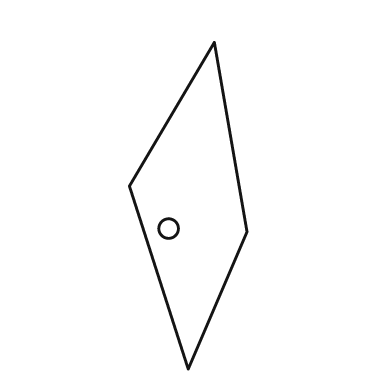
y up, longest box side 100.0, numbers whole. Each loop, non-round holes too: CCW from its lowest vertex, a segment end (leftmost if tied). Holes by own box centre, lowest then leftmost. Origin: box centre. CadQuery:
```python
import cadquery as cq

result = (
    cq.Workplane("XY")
    .moveTo(0.0, -50.0)
    .lineTo(18.0, -8.0)
    .lineTo(8.0, 50.0)
    .lineTo(-18.0, 6.0)
    .close()
    .moveTo(-6.0, -7.0)
    .circle(3.0)
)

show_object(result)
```